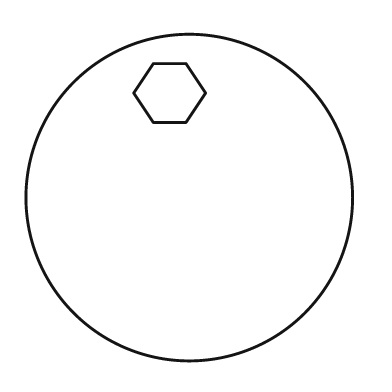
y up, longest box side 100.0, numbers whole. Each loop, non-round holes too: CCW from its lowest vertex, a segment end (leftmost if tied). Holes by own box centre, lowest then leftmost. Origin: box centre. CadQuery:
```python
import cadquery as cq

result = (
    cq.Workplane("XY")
    .moveTo(0.0, 0.0)
    .circle(50.0)
    .moveTo(-11.0, 23.0)
    .lineTo(-1.0, 23.0)
    .lineTo(5.0, 32.0)
    .lineTo(-1.0, 41.0)
    .lineTo(-11.0, 41.0)
    .lineTo(-17.0, 32.0)
    .close()
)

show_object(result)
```